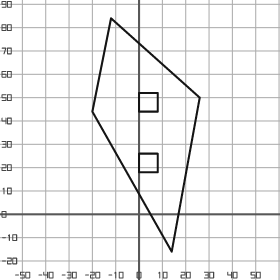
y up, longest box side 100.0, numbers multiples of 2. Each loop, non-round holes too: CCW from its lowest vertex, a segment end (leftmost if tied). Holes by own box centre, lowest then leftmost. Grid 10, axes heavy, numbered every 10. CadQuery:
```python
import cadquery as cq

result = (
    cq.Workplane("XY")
    .moveTo(14.0, -16.0)
    .lineTo(26.0, 50.0)
    .lineTo(-12.0, 84.0)
    .lineTo(-20.0, 44.0)
    .close()
    .moveTo(0.0, 18.0)
    .lineTo(8.0, 18.0)
    .lineTo(8.0, 26.0)
    .lineTo(0.0, 26.0)
    .close()
    .moveTo(0.0, 44.0)
    .lineTo(8.0, 44.0)
    .lineTo(8.0, 52.0)
    .lineTo(0.0, 52.0)
    .close()
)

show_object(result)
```